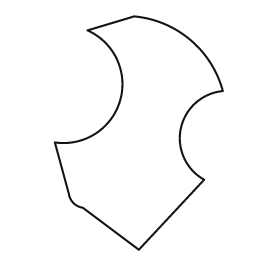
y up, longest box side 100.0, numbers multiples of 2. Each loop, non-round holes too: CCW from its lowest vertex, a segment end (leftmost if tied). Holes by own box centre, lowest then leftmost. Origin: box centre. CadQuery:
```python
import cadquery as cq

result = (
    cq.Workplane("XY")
    .moveTo(0.0, -50.0)
    .lineTo(28.0, -20.0)
    .threePointArc((18.0, 2.0), (36.0, 18.0))
    .threePointArc((22.0, 40.0), (-2.0, 50.0))
    .lineTo(-22.0, 44.0)
    .threePointArc((-8.0, 14.0), (-36.0, -4.0))
    .lineTo(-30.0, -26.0)
    .threePointArc((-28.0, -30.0), (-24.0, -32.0))
    .close()
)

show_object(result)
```